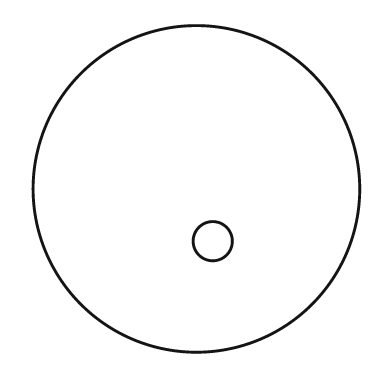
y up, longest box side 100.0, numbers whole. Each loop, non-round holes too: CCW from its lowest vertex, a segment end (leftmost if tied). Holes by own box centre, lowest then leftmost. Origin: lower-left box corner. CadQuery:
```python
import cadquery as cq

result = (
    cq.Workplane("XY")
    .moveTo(50.0, 50.0)
    .circle(50.0)
    .moveTo(55.0, 34.0)
    .circle(6.0)
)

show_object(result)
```